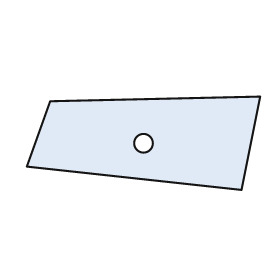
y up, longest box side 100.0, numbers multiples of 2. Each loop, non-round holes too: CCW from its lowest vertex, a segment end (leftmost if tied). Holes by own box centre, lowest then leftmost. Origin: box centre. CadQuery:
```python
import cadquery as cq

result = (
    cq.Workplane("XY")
    .moveTo(42.0, -20.0)
    .lineTo(50.0, 20.0)
    .lineTo(-40.0, 18.0)
    .lineTo(-50.0, -10.0)
    .close()
    .moveTo(0.0, 0.0)
    .circle(4.0)
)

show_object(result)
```